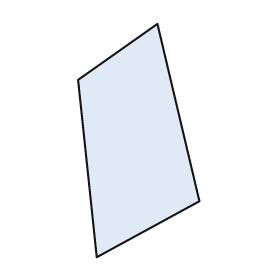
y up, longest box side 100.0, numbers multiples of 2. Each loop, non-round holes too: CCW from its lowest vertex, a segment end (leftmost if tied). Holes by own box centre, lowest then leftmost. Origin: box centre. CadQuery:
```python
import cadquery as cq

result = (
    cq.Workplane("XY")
    .moveTo(-18.0, -50.0)
    .lineTo(26.0, -26.0)
    .lineTo(8.0, 50.0)
    .lineTo(-26.0, 26.0)
    .close()
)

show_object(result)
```